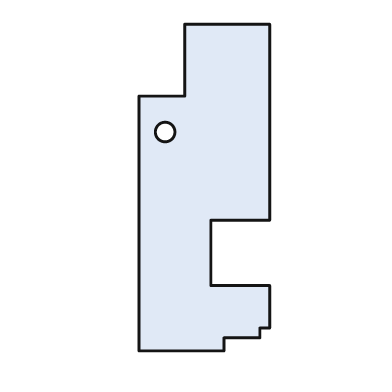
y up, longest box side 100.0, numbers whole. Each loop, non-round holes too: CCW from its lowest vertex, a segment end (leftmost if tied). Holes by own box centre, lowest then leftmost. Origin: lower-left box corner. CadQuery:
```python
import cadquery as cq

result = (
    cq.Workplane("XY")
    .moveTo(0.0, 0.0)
    .lineTo(26.0, 0.0)
    .lineTo(26.0, 4.0)
    .lineTo(37.0, 4.0)
    .lineTo(37.0, 7.0)
    .lineTo(40.0, 7.0)
    .lineTo(40.0, 20.0)
    .lineTo(22.0, 20.0)
    .lineTo(22.0, 40.0)
    .lineTo(40.0, 40.0)
    .lineTo(40.0, 100.0)
    .lineTo(14.0, 100.0)
    .lineTo(14.0, 78.0)
    .lineTo(0.0, 78.0)
    .close()
    .moveTo(8.0, 67.0)
    .circle(3.0)
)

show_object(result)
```